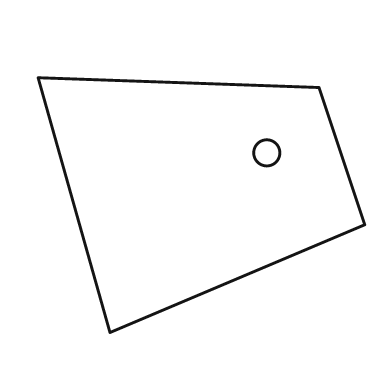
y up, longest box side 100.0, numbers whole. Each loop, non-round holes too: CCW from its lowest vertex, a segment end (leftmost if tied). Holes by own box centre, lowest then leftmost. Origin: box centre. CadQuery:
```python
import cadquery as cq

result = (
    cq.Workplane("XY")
    .moveTo(-28.0, -39.0)
    .lineTo(50.0, -6.0)
    .lineTo(36.0, 36.0)
    .lineTo(-50.0, 39.0)
    .close()
    .moveTo(20.0, 16.0)
    .circle(4.0)
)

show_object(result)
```